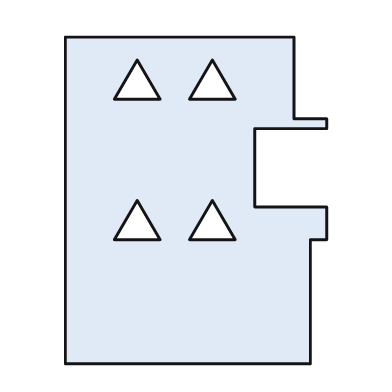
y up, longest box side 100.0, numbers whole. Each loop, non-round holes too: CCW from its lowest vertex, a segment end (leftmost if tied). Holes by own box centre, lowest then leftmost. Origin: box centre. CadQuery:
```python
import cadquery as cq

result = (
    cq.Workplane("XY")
    .moveTo(-40.0, -50.0)
    .lineTo(35.0, -50.0)
    .lineTo(35.0, -12.0)
    .lineTo(40.0, -12.0)
    .lineTo(40.0, -2.0)
    .lineTo(18.0, -2.0)
    .lineTo(18.0, 22.0)
    .lineTo(40.0, 22.0)
    .lineTo(40.0, 25.0)
    .lineTo(30.0, 25.0)
    .lineTo(30.0, 50.0)
    .lineTo(-40.0, 50.0)
    .close()
    .moveTo(-25.0, -12.0)
    .lineTo(-11.0, -12.0)
    .lineTo(-18.0, 0.0)
    .close()
    .moveTo(-2.0, -12.0)
    .lineTo(12.0, -12.0)
    .lineTo(5.0, 0.0)
    .close()
    .moveTo(-25.0, 31.0)
    .lineTo(-11.0, 31.0)
    .lineTo(-18.0, 43.0)
    .close()
    .moveTo(-2.0, 31.0)
    .lineTo(12.0, 31.0)
    .lineTo(5.0, 43.0)
    .close()
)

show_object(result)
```